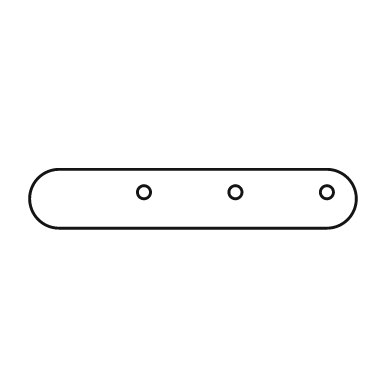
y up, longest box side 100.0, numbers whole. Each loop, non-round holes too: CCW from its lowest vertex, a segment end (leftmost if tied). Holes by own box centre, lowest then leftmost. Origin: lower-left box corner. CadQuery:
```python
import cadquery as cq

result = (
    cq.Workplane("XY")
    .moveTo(9.0, 0.0)
    .lineTo(91.0, 0.0)
    .threePointArc((100.0, 9.0), (91.0, 18.0))
    .lineTo(9.0, 18.0)
    .threePointArc((0.0, 9.0), (9.0, 0.0))
    .close()
    .moveTo(35.0, 11.0)
    .circle(2.0)
    .moveTo(63.0, 11.0)
    .circle(2.0)
    .moveTo(91.0, 11.0)
    .circle(2.0)
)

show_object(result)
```